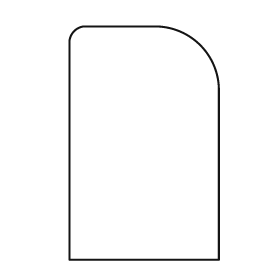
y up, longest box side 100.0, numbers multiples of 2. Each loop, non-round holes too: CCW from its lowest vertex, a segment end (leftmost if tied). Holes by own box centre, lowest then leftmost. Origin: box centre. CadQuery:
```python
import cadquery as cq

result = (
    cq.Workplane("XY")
    .moveTo(-32.0, -50.0)
    .lineTo(32.0, -50.0)
    .lineTo(32.0, 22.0)
    .threePointArc((24.0, 42.0), (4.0, 50.0))
    .lineTo(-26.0, 50.0)
    .threePointArc((-30.0, 48.0), (-32.0, 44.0))
    .close()
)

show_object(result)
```